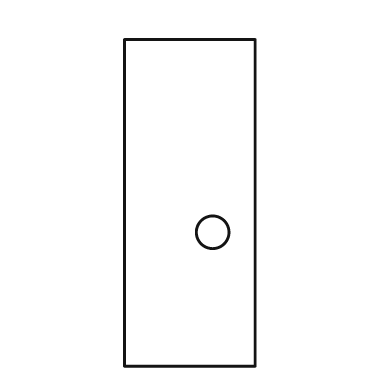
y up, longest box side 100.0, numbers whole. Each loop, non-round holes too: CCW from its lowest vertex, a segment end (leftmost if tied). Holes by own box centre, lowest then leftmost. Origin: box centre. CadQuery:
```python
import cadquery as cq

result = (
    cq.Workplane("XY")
    .moveTo(-20.0, -50.0)
    .lineTo(20.0, -50.0)
    .lineTo(20.0, 50.0)
    .lineTo(-20.0, 50.0)
    .close()
    .moveTo(7.0, -9.0)
    .circle(5.0)
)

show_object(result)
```